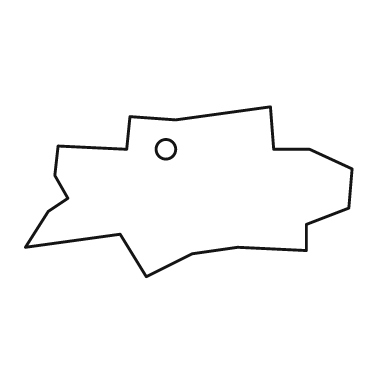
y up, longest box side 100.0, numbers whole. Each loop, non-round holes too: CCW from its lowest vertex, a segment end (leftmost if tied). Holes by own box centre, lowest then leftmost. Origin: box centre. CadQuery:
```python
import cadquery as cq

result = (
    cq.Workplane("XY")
    .moveTo(-13.0, -26.0)
    .lineTo(1.0, -19.0)
    .lineTo(15.0, -17.0)
    .lineTo(36.0, -18.0)
    .lineTo(36.0, -10.0)
    .lineTo(49.0, -5.0)
    .lineTo(50.0, 7.0)
    .lineTo(37.0, 13.0)
    .lineTo(26.0, 13.0)
    .lineTo(25.0, 26.0)
    .lineTo(-4.0, 22.0)
    .lineTo(-18.0, 23.0)
    .lineTo(-19.0, 13.0)
    .lineTo(-40.0, 14.0)
    .lineTo(-41.0, 5.0)
    .lineTo(-37.0, -2.0)
    .lineTo(-43.0, -6.0)
    .lineTo(-50.0, -17.0)
    .lineTo(-21.0, -13.0)
    .close()
    .moveTo(-7.0, 13.0)
    .circle(3.0)
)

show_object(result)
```